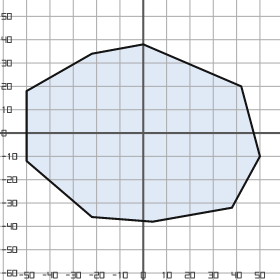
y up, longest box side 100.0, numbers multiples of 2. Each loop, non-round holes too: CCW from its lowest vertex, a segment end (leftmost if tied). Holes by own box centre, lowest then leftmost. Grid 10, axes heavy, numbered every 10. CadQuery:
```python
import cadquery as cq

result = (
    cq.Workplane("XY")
    .moveTo(4.0, -38.0)
    .lineTo(38.0, -32.0)
    .lineTo(50.0, -10.0)
    .lineTo(42.0, 20.0)
    .lineTo(0.0, 38.0)
    .lineTo(-22.0, 34.0)
    .lineTo(-50.0, 18.0)
    .lineTo(-50.0, -12.0)
    .lineTo(-22.0, -36.0)
    .close()
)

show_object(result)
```